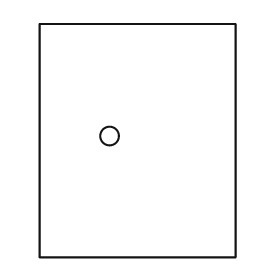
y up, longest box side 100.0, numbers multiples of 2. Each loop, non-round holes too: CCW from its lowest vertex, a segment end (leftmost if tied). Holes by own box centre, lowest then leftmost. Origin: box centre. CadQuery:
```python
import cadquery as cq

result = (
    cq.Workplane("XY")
    .moveTo(-42.0, -50.0)
    .lineTo(42.0, -50.0)
    .lineTo(42.0, 50.0)
    .lineTo(-42.0, 50.0)
    .close()
    .moveTo(-12.0, 2.0)
    .circle(4.0)
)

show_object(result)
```